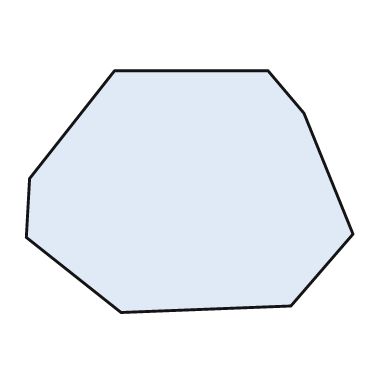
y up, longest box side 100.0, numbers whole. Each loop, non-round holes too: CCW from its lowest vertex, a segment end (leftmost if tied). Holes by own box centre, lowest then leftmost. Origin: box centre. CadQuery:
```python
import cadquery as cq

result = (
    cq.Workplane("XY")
    .moveTo(-21.0, -37.0)
    .lineTo(31.0, -35.0)
    .lineTo(50.0, -13.0)
    .lineTo(35.0, 24.0)
    .lineTo(24.0, 37.0)
    .lineTo(-23.0, 37.0)
    .lineTo(-49.0, 4.0)
    .lineTo(-50.0, -14.0)
    .close()
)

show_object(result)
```